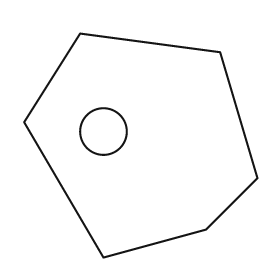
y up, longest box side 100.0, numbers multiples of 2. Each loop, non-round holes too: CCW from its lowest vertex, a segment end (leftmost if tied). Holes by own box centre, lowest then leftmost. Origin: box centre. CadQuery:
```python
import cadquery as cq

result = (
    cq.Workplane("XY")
    .moveTo(-16.0, -48.0)
    .lineTo(28.0, -36.0)
    .lineTo(50.0, -14.0)
    .lineTo(34.0, 40.0)
    .lineTo(-26.0, 48.0)
    .lineTo(-50.0, 10.0)
    .close()
    .moveTo(-16.0, 6.0)
    .circle(10.0)
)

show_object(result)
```